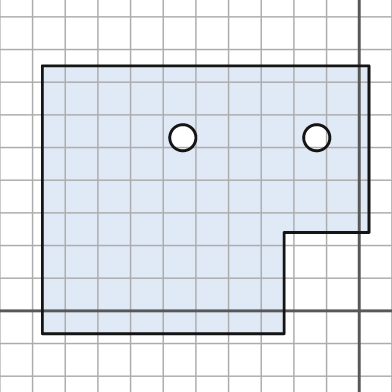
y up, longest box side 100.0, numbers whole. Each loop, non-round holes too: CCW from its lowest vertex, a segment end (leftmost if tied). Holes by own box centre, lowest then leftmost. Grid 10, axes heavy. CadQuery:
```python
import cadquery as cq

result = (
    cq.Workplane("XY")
    .moveTo(-97.0, -7.0)
    .lineTo(-23.0, -7.0)
    .lineTo(-23.0, 24.0)
    .lineTo(3.0, 24.0)
    .lineTo(3.0, 75.0)
    .lineTo(-97.0, 75.0)
    .close()
    .moveTo(-54.0, 53.0)
    .circle(4.0)
    .moveTo(-13.0, 53.0)
    .circle(4.0)
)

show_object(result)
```